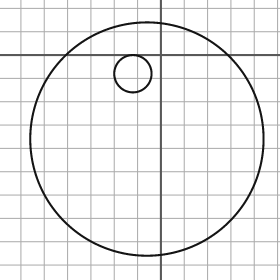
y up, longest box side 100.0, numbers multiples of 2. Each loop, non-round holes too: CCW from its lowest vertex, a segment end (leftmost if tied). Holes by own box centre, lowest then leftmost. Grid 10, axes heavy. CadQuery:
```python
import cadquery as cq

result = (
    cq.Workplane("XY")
    .moveTo(-6.0, -36.0)
    .circle(50.0)
    .moveTo(-12.0, -8.0)
    .circle(8.0)
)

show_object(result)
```